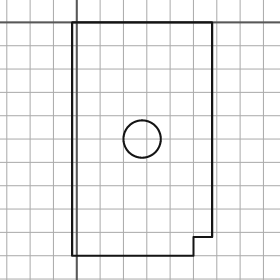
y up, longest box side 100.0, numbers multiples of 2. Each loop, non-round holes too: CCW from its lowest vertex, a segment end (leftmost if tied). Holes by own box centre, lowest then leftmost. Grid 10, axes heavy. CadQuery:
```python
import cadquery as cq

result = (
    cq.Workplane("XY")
    .moveTo(-2.0, -100.0)
    .lineTo(50.0, -100.0)
    .lineTo(50.0, -92.0)
    .lineTo(58.0, -92.0)
    .lineTo(58.0, 0.0)
    .lineTo(-2.0, 0.0)
    .close()
    .moveTo(28.0, -50.0)
    .circle(8.0)
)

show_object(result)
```